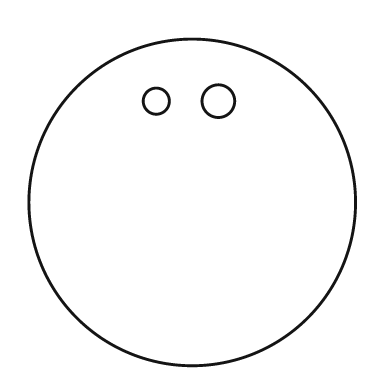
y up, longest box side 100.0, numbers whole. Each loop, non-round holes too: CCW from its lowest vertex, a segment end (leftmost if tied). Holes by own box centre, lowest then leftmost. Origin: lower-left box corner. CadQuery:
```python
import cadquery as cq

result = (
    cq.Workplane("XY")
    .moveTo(50.0, 50.0)
    .circle(50.0)
    .moveTo(39.0, 81.0)
    .circle(4.0)
    .moveTo(58.0, 81.0)
    .circle(5.0)
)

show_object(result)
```